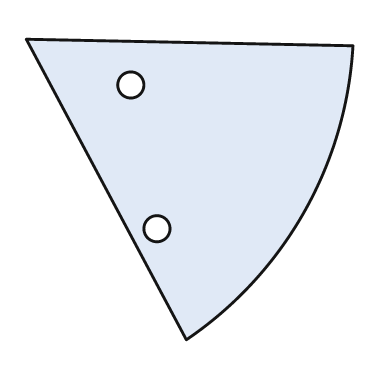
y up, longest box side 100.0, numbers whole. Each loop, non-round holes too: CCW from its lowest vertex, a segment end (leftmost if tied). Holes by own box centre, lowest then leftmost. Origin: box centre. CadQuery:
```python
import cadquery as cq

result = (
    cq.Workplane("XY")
    .moveTo(-1.0, -46.0)
    .threePointArc((35.0, -7.0), (50.0, 44.0))
    .lineTo(-50.0, 46.0)
    .close()
    .moveTo(-10.0, -12.0)
    .circle(4.0)
    .moveTo(-18.0, 32.0)
    .circle(4.0)
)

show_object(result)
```